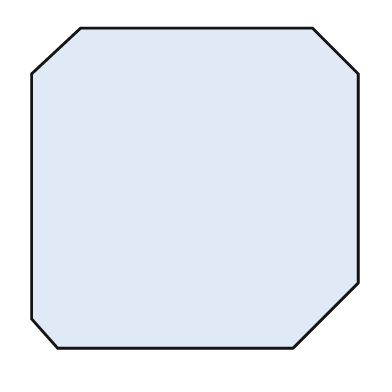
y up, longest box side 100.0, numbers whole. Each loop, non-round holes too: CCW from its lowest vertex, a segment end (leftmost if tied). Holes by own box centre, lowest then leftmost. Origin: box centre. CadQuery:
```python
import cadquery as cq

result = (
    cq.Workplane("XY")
    .moveTo(-42.0, -49.0)
    .lineTo(30.0, -49.0)
    .lineTo(50.0, -29.0)
    .lineTo(50.0, 35.0)
    .lineTo(36.0, 49.0)
    .lineTo(-35.0, 49.0)
    .lineTo(-50.0, 35.0)
    .lineTo(-50.0, -40.0)
    .close()
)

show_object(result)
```